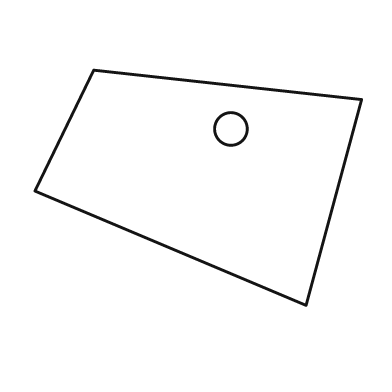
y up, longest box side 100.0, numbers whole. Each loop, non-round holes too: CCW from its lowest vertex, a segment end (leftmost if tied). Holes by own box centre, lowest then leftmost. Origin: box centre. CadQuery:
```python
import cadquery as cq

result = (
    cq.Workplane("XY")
    .moveTo(33.0, -36.0)
    .lineTo(50.0, 27.0)
    .lineTo(-32.0, 36.0)
    .lineTo(-50.0, -1.0)
    .close()
    .moveTo(10.0, 18.0)
    .circle(5.0)
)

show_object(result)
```